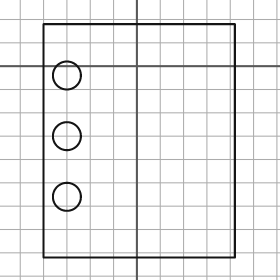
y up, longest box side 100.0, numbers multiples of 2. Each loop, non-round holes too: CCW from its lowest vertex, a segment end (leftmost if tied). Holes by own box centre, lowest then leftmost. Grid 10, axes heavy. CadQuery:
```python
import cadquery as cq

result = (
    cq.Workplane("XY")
    .moveTo(-40.0, -82.0)
    .lineTo(42.0, -82.0)
    .lineTo(42.0, 18.0)
    .lineTo(-40.0, 18.0)
    .close()
    .moveTo(-30.0, -56.0)
    .circle(6.0)
    .moveTo(-30.0, -30.0)
    .circle(6.0)
    .moveTo(-30.0, -4.0)
    .circle(6.0)
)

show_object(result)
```